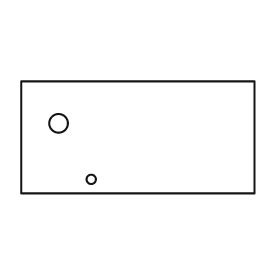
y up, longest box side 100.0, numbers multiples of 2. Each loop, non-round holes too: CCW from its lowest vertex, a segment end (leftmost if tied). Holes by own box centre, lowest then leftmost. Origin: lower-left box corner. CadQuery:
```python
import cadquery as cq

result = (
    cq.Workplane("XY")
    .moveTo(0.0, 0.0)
    .lineTo(100.0, 0.0)
    .lineTo(100.0, 48.0)
    .lineTo(0.0, 48.0)
    .close()
    .moveTo(30.0, 6.0)
    .circle(2.0)
    .moveTo(16.0, 30.0)
    .circle(4.0)
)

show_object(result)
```